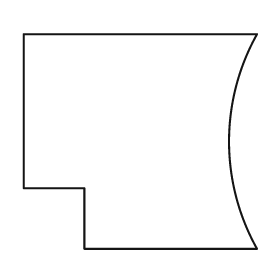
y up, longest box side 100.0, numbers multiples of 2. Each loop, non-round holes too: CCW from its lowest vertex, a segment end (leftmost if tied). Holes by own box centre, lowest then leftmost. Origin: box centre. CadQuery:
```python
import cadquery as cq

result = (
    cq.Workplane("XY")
    .moveTo(-24.0, -46.0)
    .lineTo(50.0, -46.0)
    .threePointArc((38.0, 0.0), (50.0, 46.0))
    .lineTo(-50.0, 46.0)
    .lineTo(-50.0, -20.0)
    .lineTo(-24.0, -20.0)
    .close()
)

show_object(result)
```